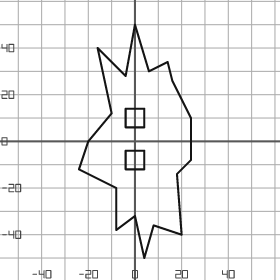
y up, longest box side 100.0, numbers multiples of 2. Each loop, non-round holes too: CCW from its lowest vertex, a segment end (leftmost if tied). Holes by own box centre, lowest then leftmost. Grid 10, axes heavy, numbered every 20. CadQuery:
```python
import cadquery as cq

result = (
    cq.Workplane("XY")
    .moveTo(4.0, -50.0)
    .lineTo(8.0, -36.0)
    .lineTo(20.0, -40.0)
    .lineTo(18.0, -14.0)
    .lineTo(24.0, -8.0)
    .lineTo(24.0, 10.0)
    .lineTo(16.0, 26.0)
    .lineTo(14.0, 34.0)
    .lineTo(6.0, 30.0)
    .lineTo(0.0, 50.0)
    .lineTo(-4.0, 28.0)
    .lineTo(-16.0, 40.0)
    .lineTo(-10.0, 12.0)
    .lineTo(-20.0, 0.0)
    .lineTo(-24.0, -12.0)
    .lineTo(-8.0, -20.0)
    .lineTo(-8.0, -38.0)
    .lineTo(0.0, -32.0)
    .close()
    .moveTo(-4.0, -12.0)
    .lineTo(4.0, -12.0)
    .lineTo(4.0, -4.0)
    .lineTo(-4.0, -4.0)
    .close()
    .moveTo(-4.0, 6.0)
    .lineTo(4.0, 6.0)
    .lineTo(4.0, 14.0)
    .lineTo(-4.0, 14.0)
    .close()
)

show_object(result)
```